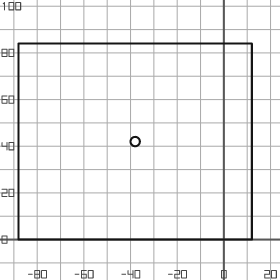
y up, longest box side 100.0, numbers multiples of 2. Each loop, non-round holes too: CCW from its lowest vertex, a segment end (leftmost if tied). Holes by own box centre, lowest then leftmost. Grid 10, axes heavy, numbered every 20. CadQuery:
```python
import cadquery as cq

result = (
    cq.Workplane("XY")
    .moveTo(-88.0, 0.0)
    .lineTo(12.0, 0.0)
    .lineTo(12.0, 84.0)
    .lineTo(-88.0, 84.0)
    .close()
    .moveTo(-38.0, 42.0)
    .circle(2.0)
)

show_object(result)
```